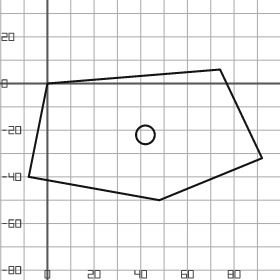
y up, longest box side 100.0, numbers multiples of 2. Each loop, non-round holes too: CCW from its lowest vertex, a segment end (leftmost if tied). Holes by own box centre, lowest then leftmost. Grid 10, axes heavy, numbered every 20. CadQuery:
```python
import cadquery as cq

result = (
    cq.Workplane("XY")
    .moveTo(48.0, -50.0)
    .lineTo(92.0, -32.0)
    .lineTo(74.0, 6.0)
    .lineTo(0.0, 0.0)
    .lineTo(-8.0, -40.0)
    .close()
    .moveTo(42.0, -22.0)
    .circle(4.0)
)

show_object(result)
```